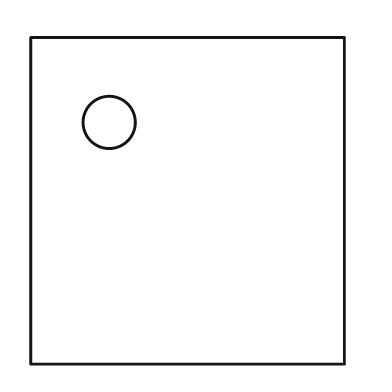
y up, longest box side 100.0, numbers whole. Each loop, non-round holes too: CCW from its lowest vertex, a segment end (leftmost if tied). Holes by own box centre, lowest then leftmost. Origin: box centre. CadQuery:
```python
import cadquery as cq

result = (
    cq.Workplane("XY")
    .moveTo(-48.0, -50.0)
    .lineTo(48.0, -50.0)
    .lineTo(48.0, 50.0)
    .lineTo(-48.0, 50.0)
    .close()
    .moveTo(-24.0, 24.0)
    .circle(8.0)
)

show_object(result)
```